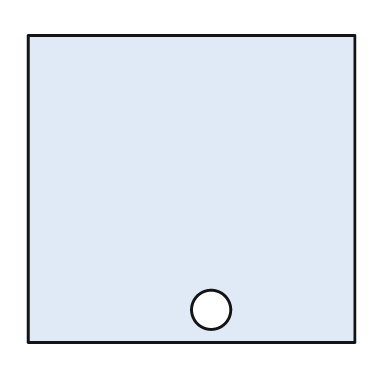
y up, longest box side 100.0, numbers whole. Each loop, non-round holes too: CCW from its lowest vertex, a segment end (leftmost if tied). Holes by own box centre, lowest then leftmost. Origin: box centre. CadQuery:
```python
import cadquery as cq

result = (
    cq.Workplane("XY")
    .moveTo(-50.0, -47.0)
    .lineTo(50.0, -47.0)
    .lineTo(50.0, 47.0)
    .lineTo(-50.0, 47.0)
    .close()
    .moveTo(6.0, -37.0)
    .circle(6.0)
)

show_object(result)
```